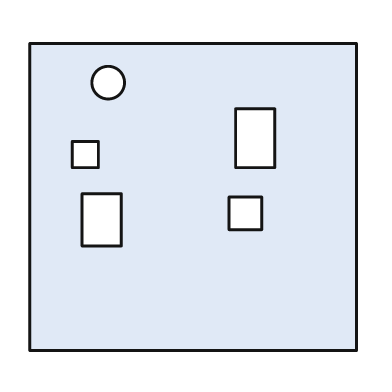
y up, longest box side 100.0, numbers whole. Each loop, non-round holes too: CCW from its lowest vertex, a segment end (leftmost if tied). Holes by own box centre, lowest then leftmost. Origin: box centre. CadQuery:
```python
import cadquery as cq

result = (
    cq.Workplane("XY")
    .moveTo(-50.0, -47.0)
    .lineTo(50.0, -47.0)
    .lineTo(50.0, 47.0)
    .lineTo(-50.0, 47.0)
    .close()
    .moveTo(-34.0, -15.0)
    .lineTo(-22.0, -15.0)
    .lineTo(-22.0, 1.0)
    .lineTo(-34.0, 1.0)
    .close()
    .moveTo(11.0, -10.0)
    .lineTo(21.0, -10.0)
    .lineTo(21.0, 0.0)
    .lineTo(11.0, 0.0)
    .close()
    .moveTo(-37.0, 9.0)
    .lineTo(-29.0, 9.0)
    .lineTo(-29.0, 17.0)
    .lineTo(-37.0, 17.0)
    .close()
    .moveTo(13.0, 9.0)
    .lineTo(25.0, 9.0)
    .lineTo(25.0, 27.0)
    .lineTo(13.0, 27.0)
    .close()
    .moveTo(-26.0, 35.0)
    .circle(5.0)
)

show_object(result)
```